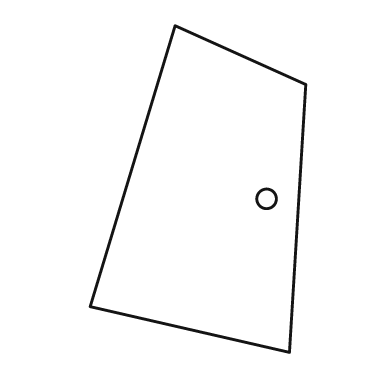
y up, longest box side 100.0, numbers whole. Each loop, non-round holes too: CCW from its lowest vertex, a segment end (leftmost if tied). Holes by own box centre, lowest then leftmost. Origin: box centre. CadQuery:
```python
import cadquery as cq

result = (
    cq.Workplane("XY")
    .moveTo(28.0, -50.0)
    .lineTo(33.0, 32.0)
    .lineTo(-7.0, 50.0)
    .lineTo(-33.0, -36.0)
    .close()
    .moveTo(21.0, -3.0)
    .circle(3.0)
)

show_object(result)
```